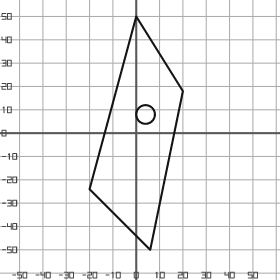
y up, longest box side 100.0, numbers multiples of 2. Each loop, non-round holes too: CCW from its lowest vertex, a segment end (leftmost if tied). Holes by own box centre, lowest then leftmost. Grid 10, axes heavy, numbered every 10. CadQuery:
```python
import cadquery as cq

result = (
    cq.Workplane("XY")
    .moveTo(6.0, -50.0)
    .lineTo(20.0, 18.0)
    .lineTo(0.0, 50.0)
    .lineTo(-20.0, -24.0)
    .close()
    .moveTo(4.0, 8.0)
    .circle(4.0)
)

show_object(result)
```